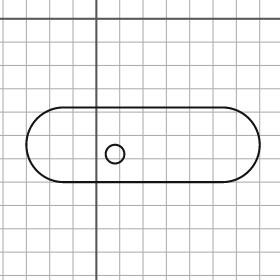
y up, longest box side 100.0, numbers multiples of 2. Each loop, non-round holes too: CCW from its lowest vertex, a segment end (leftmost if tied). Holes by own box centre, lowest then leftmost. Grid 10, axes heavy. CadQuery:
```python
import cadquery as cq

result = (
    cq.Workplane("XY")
    .moveTo(-14.0, -70.0)
    .lineTo(54.0, -70.0)
    .threePointArc((70.0, -54.0), (54.0, -38.0))
    .lineTo(-14.0, -38.0)
    .threePointArc((-30.0, -54.0), (-14.0, -70.0))
    .close()
    .moveTo(8.0, -58.0)
    .circle(4.0)
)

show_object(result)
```